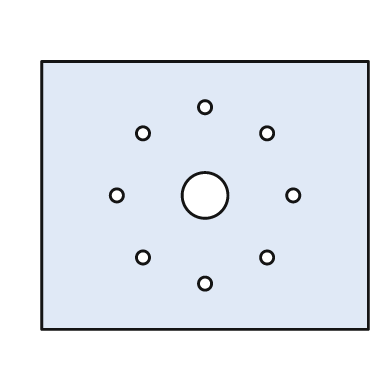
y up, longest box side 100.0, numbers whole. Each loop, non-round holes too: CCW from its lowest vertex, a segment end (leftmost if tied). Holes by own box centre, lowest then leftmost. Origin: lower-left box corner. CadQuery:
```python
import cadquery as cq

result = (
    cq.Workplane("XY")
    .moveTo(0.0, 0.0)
    .lineTo(100.0, 0.0)
    .lineTo(100.0, 82.0)
    .lineTo(0.0, 82.0)
    .close()
    .moveTo(50.0, 14.0)
    .circle(2.0)
    .moveTo(31.0, 22.0)
    .circle(2.0)
    .moveTo(69.0, 22.0)
    .circle(2.0)
    .moveTo(23.0, 41.0)
    .circle(2.0)
    .moveTo(50.0, 41.0)
    .circle(7.0)
    .moveTo(77.0, 41.0)
    .circle(2.0)
    .moveTo(31.0, 60.0)
    .circle(2.0)
    .moveTo(69.0, 60.0)
    .circle(2.0)
    .moveTo(50.0, 68.0)
    .circle(2.0)
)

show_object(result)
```